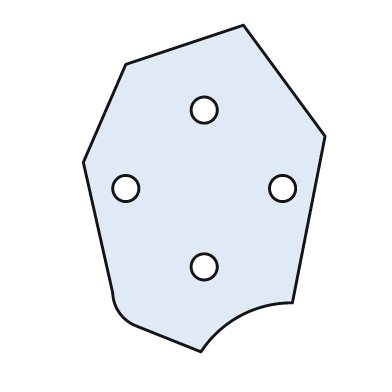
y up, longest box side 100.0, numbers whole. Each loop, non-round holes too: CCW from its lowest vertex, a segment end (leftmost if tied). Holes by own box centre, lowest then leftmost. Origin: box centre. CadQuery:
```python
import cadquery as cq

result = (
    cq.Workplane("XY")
    .moveTo(-1.0, -50.0)
    .threePointArc((11.0, -39.0), (27.0, -35.0))
    .lineTo(37.0, 16.0)
    .lineTo(12.0, 50.0)
    .lineTo(-24.0, 38.0)
    .lineTo(-37.0, 8.0)
    .lineTo(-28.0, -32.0)
    .threePointArc((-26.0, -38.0), (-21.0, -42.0))
    .close()
    .moveTo(0.0, -24.0)
    .circle(4.0)
    .moveTo(-24.0, 0.0)
    .circle(4.0)
    .moveTo(24.0, 0.0)
    .circle(4.0)
    .moveTo(0.0, 24.0)
    .circle(4.0)
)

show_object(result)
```